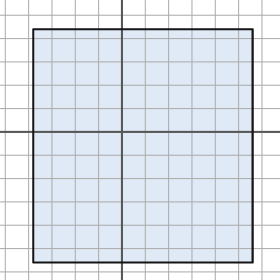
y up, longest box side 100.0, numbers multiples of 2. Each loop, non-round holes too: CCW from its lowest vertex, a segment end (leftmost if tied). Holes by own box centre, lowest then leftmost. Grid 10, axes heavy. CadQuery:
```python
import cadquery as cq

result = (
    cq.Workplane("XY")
    .moveTo(-38.0, -56.0)
    .lineTo(56.0, -56.0)
    .lineTo(56.0, 44.0)
    .lineTo(-38.0, 44.0)
    .close()
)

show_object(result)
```